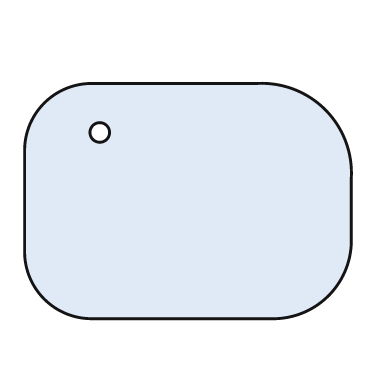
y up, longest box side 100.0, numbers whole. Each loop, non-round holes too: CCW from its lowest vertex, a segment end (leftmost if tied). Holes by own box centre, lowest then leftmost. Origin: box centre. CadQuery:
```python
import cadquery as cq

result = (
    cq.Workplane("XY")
    .moveTo(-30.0, -36.0)
    .lineTo(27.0, -36.0)
    .threePointArc((43.0, -29.0), (50.0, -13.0))
    .lineTo(50.0, 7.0)
    .threePointArc((42.0, 28.0), (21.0, 36.0))
    .lineTo(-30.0, 36.0)
    .threePointArc((-44.0, 30.0), (-50.0, 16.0))
    .lineTo(-50.0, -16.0)
    .threePointArc((-44.0, -30.0), (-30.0, -36.0))
    .close()
    .moveTo(-27.0, 21.0)
    .circle(3.0)
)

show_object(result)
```